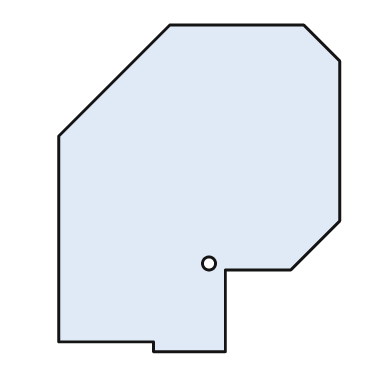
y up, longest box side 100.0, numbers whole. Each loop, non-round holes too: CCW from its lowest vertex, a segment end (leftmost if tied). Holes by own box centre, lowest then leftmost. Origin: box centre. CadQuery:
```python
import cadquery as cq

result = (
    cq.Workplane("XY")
    .moveTo(-14.0, -50.0)
    .lineTo(8.0, -50.0)
    .lineTo(8.0, -25.0)
    .lineTo(28.0, -25.0)
    .lineTo(43.0, -10.0)
    .lineTo(43.0, 39.0)
    .lineTo(32.0, 50.0)
    .lineTo(-9.0, 50.0)
    .lineTo(-43.0, 16.0)
    .lineTo(-43.0, -47.0)
    .lineTo(-14.0, -47.0)
    .close()
    .moveTo(3.0, -23.0)
    .circle(2.0)
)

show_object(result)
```